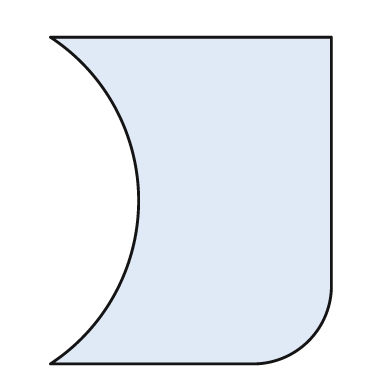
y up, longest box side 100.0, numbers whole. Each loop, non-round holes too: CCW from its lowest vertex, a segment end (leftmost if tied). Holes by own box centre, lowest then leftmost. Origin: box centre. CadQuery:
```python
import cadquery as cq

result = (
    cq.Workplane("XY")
    .moveTo(-43.0, -50.0)
    .lineTo(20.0, -50.0)
    .threePointArc((36.0, -43.0), (43.0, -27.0))
    .lineTo(43.0, 50.0)
    .lineTo(-43.0, 50.0)
    .threePointArc((-16.0, 0.0), (-43.0, -50.0))
    .close()
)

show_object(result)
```